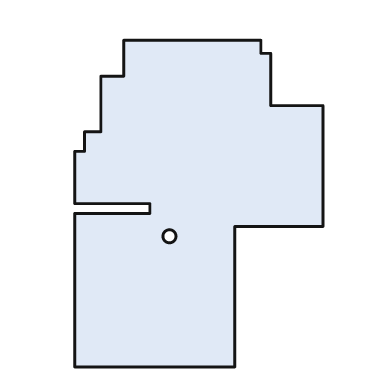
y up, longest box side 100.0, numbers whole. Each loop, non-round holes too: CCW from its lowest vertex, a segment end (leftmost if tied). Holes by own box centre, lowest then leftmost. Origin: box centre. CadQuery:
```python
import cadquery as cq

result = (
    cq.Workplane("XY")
    .moveTo(-38.0, -50.0)
    .lineTo(11.0, -50.0)
    .lineTo(11.0, -7.0)
    .lineTo(38.0, -7.0)
    .lineTo(38.0, 30.0)
    .lineTo(22.0, 30.0)
    .lineTo(22.0, 46.0)
    .lineTo(19.0, 46.0)
    .lineTo(19.0, 50.0)
    .lineTo(-23.0, 50.0)
    .lineTo(-23.0, 39.0)
    .lineTo(-30.0, 39.0)
    .lineTo(-30.0, 22.0)
    .lineTo(-35.0, 22.0)
    .lineTo(-35.0, 16.0)
    .lineTo(-38.0, 16.0)
    .lineTo(-38.0, 0.0)
    .lineTo(-15.0, 0.0)
    .lineTo(-15.0, -3.0)
    .lineTo(-38.0, -3.0)
    .close()
    .moveTo(-9.0, -10.0)
    .circle(2.0)
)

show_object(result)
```